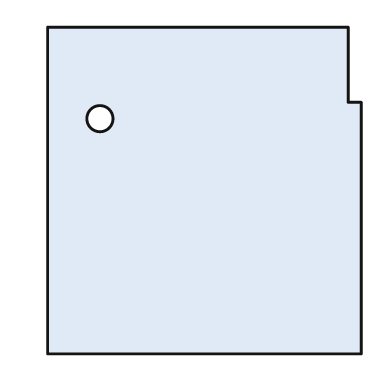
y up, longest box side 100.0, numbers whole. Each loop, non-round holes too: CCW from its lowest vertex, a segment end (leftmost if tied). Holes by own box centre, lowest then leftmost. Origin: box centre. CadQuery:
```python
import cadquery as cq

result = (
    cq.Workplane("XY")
    .moveTo(-48.0, -50.0)
    .lineTo(48.0, -50.0)
    .lineTo(48.0, 27.0)
    .lineTo(44.0, 27.0)
    .lineTo(44.0, 50.0)
    .lineTo(-48.0, 50.0)
    .close()
    .moveTo(-32.0, 22.0)
    .circle(4.0)
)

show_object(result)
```